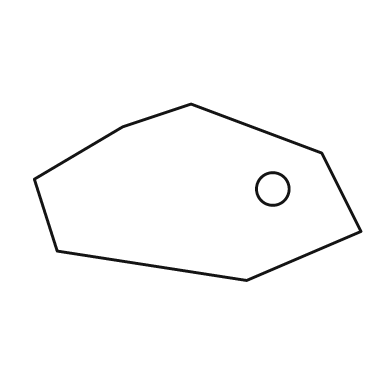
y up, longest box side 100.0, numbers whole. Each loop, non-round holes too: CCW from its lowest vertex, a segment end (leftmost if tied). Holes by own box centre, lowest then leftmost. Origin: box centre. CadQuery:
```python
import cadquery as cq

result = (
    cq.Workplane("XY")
    .moveTo(15.0, -27.0)
    .lineTo(50.0, -12.0)
    .lineTo(38.0, 12.0)
    .lineTo(-2.0, 27.0)
    .lineTo(-23.0, 20.0)
    .lineTo(-50.0, 4.0)
    .lineTo(-43.0, -18.0)
    .close()
    .moveTo(23.0, 1.0)
    .circle(5.0)
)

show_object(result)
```